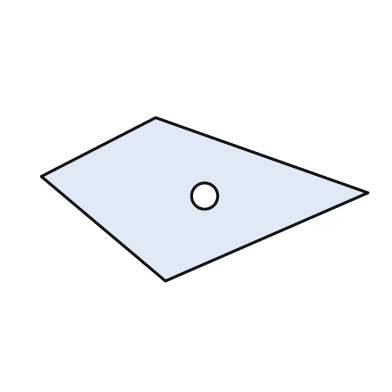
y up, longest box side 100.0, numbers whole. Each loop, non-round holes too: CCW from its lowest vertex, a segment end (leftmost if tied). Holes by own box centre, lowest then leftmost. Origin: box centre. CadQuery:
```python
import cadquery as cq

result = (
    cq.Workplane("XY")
    .moveTo(-12.0, -25.0)
    .lineTo(50.0, 2.0)
    .lineTo(-15.0, 25.0)
    .lineTo(-50.0, 7.0)
    .close()
    .moveTo(0.0, 1.0)
    .circle(4.0)
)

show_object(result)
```